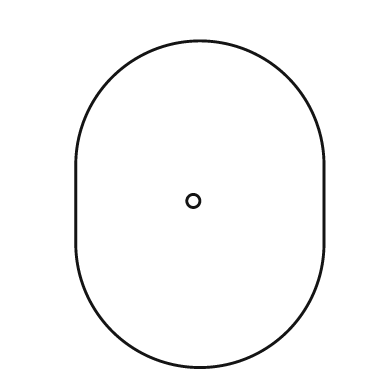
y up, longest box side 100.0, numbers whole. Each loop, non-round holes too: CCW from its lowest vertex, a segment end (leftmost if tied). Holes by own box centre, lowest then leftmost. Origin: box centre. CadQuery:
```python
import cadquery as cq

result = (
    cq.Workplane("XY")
    .moveTo(-38.0, -12.0)
    .threePointArc((0.0, -50.0), (38.0, -12.0))
    .lineTo(38.0, 12.0)
    .threePointArc((0.0, 50.0), (-38.0, 12.0))
    .close()
    .moveTo(-2.0, 1.0)
    .circle(2.0)
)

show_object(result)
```